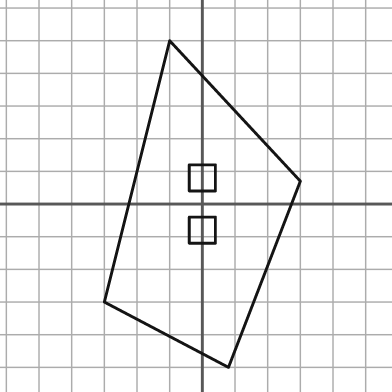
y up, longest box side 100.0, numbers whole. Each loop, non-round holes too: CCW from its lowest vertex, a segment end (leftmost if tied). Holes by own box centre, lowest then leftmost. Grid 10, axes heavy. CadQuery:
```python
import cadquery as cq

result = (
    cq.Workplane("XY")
    .moveTo(8.0, -50.0)
    .lineTo(30.0, 7.0)
    .lineTo(-10.0, 50.0)
    .lineTo(-30.0, -30.0)
    .close()
    .moveTo(-4.0, -12.0)
    .lineTo(4.0, -12.0)
    .lineTo(4.0, -4.0)
    .lineTo(-4.0, -4.0)
    .close()
    .moveTo(-4.0, 4.0)
    .lineTo(4.0, 4.0)
    .lineTo(4.0, 12.0)
    .lineTo(-4.0, 12.0)
    .close()
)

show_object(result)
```